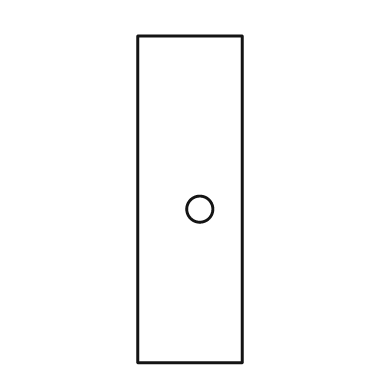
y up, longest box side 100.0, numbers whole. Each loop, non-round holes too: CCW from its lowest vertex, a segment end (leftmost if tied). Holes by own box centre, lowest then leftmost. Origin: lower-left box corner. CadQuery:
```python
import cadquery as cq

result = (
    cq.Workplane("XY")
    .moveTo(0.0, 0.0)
    .lineTo(32.0, 0.0)
    .lineTo(32.0, 100.0)
    .lineTo(0.0, 100.0)
    .close()
    .moveTo(19.0, 47.0)
    .circle(4.0)
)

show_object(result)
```